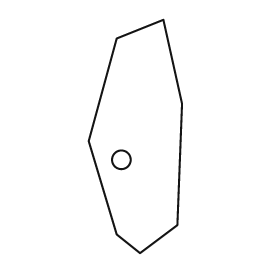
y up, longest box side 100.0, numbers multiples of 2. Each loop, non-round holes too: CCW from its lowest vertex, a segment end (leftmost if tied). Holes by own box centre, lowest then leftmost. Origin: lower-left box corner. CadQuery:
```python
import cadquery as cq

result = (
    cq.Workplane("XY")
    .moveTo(22.0, 0.0)
    .lineTo(38.0, 12.0)
    .lineTo(40.0, 64.0)
    .lineTo(32.0, 100.0)
    .lineTo(12.0, 92.0)
    .lineTo(0.0, 48.0)
    .lineTo(12.0, 8.0)
    .close()
    .moveTo(14.0, 40.0)
    .circle(4.0)
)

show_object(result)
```